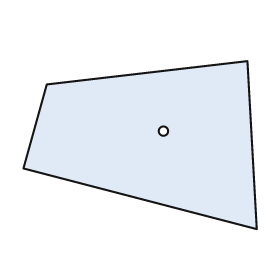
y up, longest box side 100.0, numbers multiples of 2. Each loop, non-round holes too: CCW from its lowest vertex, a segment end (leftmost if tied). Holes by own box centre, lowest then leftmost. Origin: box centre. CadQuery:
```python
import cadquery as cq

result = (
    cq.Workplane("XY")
    .moveTo(50.0, -36.0)
    .lineTo(46.0, 36.0)
    .lineTo(-40.0, 26.0)
    .lineTo(-50.0, -10.0)
    .close()
    .moveTo(10.0, 6.0)
    .circle(2.0)
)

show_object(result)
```